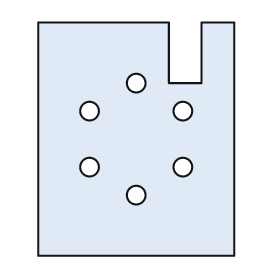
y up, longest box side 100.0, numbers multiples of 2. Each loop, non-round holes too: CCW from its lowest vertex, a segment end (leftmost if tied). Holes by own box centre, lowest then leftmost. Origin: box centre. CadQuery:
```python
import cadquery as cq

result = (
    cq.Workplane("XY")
    .moveTo(-42.0, -50.0)
    .lineTo(42.0, -50.0)
    .lineTo(42.0, 50.0)
    .lineTo(28.0, 50.0)
    .lineTo(28.0, 24.0)
    .lineTo(14.0, 24.0)
    .lineTo(14.0, 50.0)
    .lineTo(-42.0, 50.0)
    .close()
    .moveTo(0.0, -24.0)
    .circle(4.0)
    .moveTo(-20.0, -12.0)
    .circle(4.0)
    .moveTo(20.0, -12.0)
    .circle(4.0)
    .moveTo(-20.0, 12.0)
    .circle(4.0)
    .moveTo(20.0, 12.0)
    .circle(4.0)
    .moveTo(0.0, 24.0)
    .circle(4.0)
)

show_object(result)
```